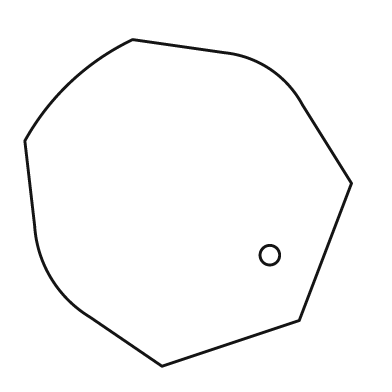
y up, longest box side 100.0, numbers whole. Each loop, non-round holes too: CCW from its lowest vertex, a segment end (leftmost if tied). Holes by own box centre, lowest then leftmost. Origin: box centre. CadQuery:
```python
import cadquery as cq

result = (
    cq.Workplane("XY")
    .moveTo(-8.0, -50.0)
    .lineTo(34.0, -36.0)
    .lineTo(50.0, 6.0)
    .lineTo(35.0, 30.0)
    .threePointArc((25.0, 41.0), (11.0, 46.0))
    .lineTo(-17.0, 50.0)
    .threePointArc((-36.0, 37.0), (-50.0, 19.0))
    .lineTo(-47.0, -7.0)
    .threePointArc((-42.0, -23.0), (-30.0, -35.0))
    .close()
    .moveTo(25.0, -16.0)
    .circle(3.0)
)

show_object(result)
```